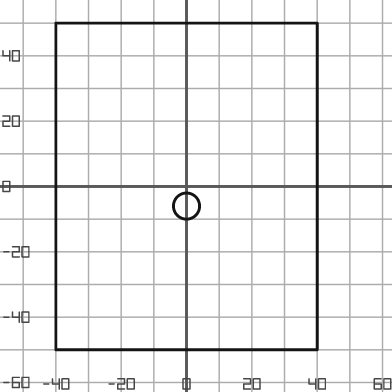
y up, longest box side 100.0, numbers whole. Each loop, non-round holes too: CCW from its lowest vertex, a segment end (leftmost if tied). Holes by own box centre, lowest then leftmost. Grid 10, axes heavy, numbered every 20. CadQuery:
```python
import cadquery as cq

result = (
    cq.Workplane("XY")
    .moveTo(-40.0, -50.0)
    .lineTo(40.0, -50.0)
    .lineTo(40.0, 50.0)
    .lineTo(-40.0, 50.0)
    .close()
    .moveTo(0.0, -6.0)
    .circle(4.0)
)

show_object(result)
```